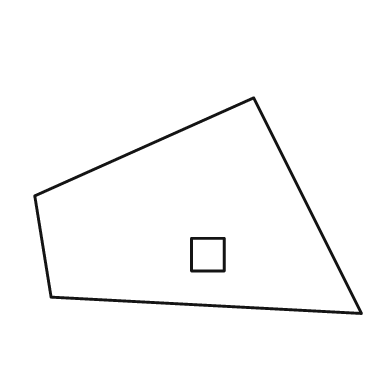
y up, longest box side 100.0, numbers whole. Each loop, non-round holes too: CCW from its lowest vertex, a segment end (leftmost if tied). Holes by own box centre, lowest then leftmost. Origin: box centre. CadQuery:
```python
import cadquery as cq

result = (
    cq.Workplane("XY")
    .moveTo(50.0, -33.0)
    .lineTo(17.0, 33.0)
    .lineTo(-50.0, 3.0)
    .lineTo(-45.0, -28.0)
    .close()
    .moveTo(-2.0, -20.0)
    .lineTo(8.0, -20.0)
    .lineTo(8.0, -10.0)
    .lineTo(-2.0, -10.0)
    .close()
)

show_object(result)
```